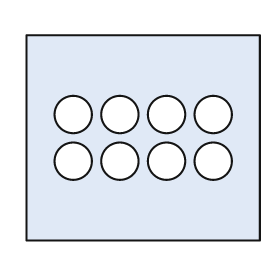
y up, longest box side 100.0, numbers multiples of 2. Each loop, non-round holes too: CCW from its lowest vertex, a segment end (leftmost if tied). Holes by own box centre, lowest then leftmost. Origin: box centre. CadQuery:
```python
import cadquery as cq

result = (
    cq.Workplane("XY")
    .moveTo(-50.0, -44.0)
    .lineTo(50.0, -44.0)
    .lineTo(50.0, 44.0)
    .lineTo(-50.0, 44.0)
    .close()
    .moveTo(-30.0, -10.0)
    .circle(8.0)
    .moveTo(-10.0, -10.0)
    .circle(8.0)
    .moveTo(10.0, -10.0)
    .circle(8.0)
    .moveTo(30.0, -10.0)
    .circle(8.0)
    .moveTo(-30.0, 10.0)
    .circle(8.0)
    .moveTo(-10.0, 10.0)
    .circle(8.0)
    .moveTo(10.0, 10.0)
    .circle(8.0)
    .moveTo(30.0, 10.0)
    .circle(8.0)
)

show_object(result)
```